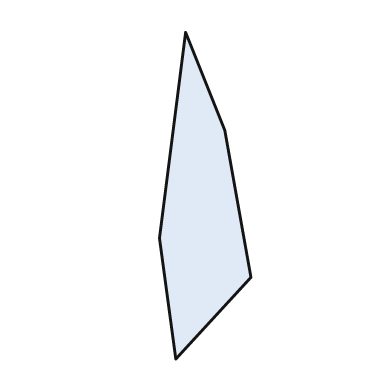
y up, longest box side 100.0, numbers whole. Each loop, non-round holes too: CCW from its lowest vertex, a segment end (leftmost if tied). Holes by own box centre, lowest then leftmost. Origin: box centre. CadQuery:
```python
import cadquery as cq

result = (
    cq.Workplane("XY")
    .moveTo(-9.0, -50.0)
    .lineTo(14.0, -25.0)
    .lineTo(6.0, 20.0)
    .lineTo(-6.0, 50.0)
    .lineTo(-14.0, -13.0)
    .close()
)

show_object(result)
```